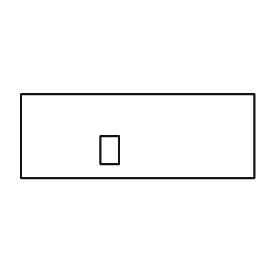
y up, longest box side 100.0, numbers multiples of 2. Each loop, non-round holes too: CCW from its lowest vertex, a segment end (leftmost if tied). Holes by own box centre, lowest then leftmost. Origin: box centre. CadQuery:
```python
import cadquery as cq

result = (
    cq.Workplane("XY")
    .moveTo(-50.0, -18.0)
    .lineTo(50.0, -18.0)
    .lineTo(50.0, 18.0)
    .lineTo(-50.0, 18.0)
    .close()
    .moveTo(-16.0, -12.0)
    .lineTo(-8.0, -12.0)
    .lineTo(-8.0, 0.0)
    .lineTo(-16.0, 0.0)
    .close()
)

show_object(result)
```